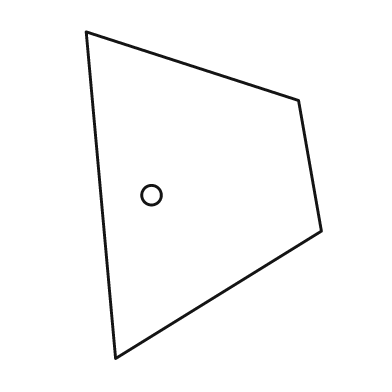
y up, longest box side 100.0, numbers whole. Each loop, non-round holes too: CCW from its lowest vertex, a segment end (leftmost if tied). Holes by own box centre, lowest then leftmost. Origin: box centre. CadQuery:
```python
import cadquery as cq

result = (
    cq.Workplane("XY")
    .moveTo(-27.0, -50.0)
    .lineTo(36.0, -11.0)
    .lineTo(29.0, 29.0)
    .lineTo(-36.0, 50.0)
    .close()
    .moveTo(-16.0, 0.0)
    .circle(3.0)
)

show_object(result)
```